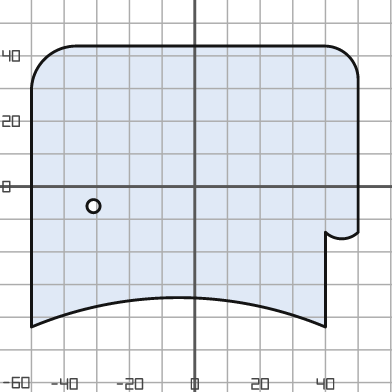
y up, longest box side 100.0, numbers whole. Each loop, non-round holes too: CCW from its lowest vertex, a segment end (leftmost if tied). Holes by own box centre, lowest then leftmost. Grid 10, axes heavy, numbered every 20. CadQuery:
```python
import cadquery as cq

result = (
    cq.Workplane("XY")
    .moveTo(-50.0, -43.0)
    .threePointArc((-5.0, -34.0), (40.0, -43.0))
    .lineTo(40.0, -14.0)
    .threePointArc((45.0, -16.0), (50.0, -14.0))
    .lineTo(50.0, 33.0)
    .threePointArc((47.0, 40.0), (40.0, 43.0))
    .lineTo(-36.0, 43.0)
    .threePointArc((-46.0, 39.0), (-50.0, 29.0))
    .close()
    .moveTo(-31.0, -6.0)
    .circle(2.0)
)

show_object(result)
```